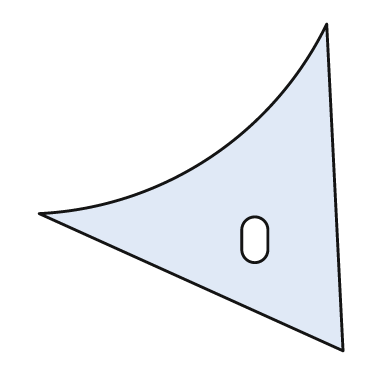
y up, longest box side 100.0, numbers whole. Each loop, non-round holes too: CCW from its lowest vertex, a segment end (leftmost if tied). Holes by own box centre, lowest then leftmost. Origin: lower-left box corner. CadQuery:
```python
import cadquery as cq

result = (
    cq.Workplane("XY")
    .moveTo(93.0, 0.0)
    .lineTo(88.0, 100.0)
    .threePointArc((52.0, 59.0), (0.0, 42.0))
    .close()
    .moveTo(62.0, 31.0)
    .threePointArc((66.0, 27.0), (70.0, 31.0))
    .lineTo(70.0, 37.0)
    .threePointArc((66.0, 41.0), (62.0, 37.0))
    .close()
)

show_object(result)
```